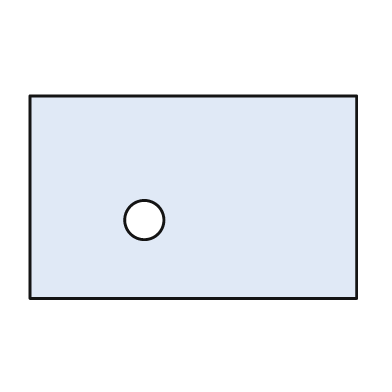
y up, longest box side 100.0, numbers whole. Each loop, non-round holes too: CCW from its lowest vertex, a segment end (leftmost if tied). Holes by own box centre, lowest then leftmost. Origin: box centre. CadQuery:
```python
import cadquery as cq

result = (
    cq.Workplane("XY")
    .moveTo(-50.0, -31.0)
    .lineTo(50.0, -31.0)
    .lineTo(50.0, 31.0)
    .lineTo(-50.0, 31.0)
    .close()
    .moveTo(-15.0, -7.0)
    .circle(6.0)
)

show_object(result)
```